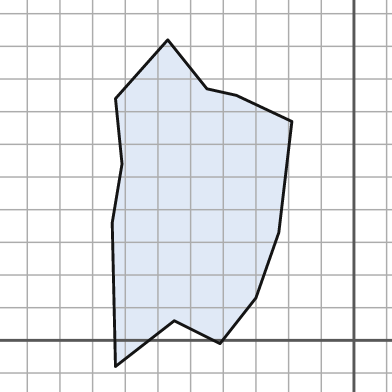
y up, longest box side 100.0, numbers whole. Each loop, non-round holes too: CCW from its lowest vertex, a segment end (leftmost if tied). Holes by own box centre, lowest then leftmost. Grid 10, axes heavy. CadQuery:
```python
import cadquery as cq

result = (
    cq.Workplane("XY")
    .moveTo(-73.0, -8.0)
    .lineTo(-55.0, 6.0)
    .lineTo(-41.0, -1.0)
    .lineTo(-30.0, 13.0)
    .lineTo(-23.0, 33.0)
    .lineTo(-19.0, 67.0)
    .lineTo(-36.0, 75.0)
    .lineTo(-45.0, 77.0)
    .lineTo(-57.0, 92.0)
    .lineTo(-73.0, 74.0)
    .lineTo(-71.0, 54.0)
    .lineTo(-74.0, 36.0)
    .close()
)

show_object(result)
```